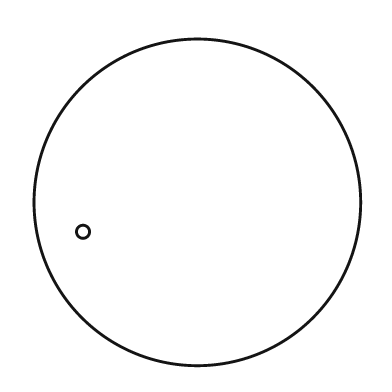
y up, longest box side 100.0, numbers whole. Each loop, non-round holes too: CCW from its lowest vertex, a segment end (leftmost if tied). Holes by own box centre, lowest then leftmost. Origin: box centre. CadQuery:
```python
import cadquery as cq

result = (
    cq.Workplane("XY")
    .moveTo(0.0, 0.0)
    .circle(50.0)
    .moveTo(-35.0, -9.0)
    .circle(2.0)
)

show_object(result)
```